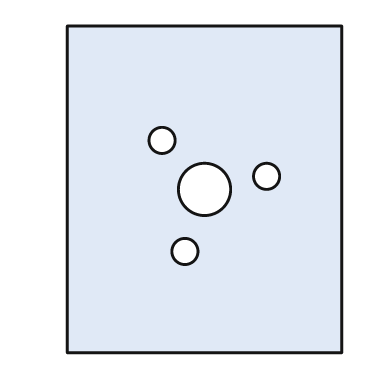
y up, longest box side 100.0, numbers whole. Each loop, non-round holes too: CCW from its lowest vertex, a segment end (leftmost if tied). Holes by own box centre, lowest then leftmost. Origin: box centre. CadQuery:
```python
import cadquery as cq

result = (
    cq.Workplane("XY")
    .moveTo(-42.0, -50.0)
    .lineTo(42.0, -50.0)
    .lineTo(42.0, 50.0)
    .lineTo(-42.0, 50.0)
    .close()
    .moveTo(-6.0, -19.0)
    .circle(4.0)
    .moveTo(0.0, 0.0)
    .circle(8.0)
    .moveTo(19.0, 4.0)
    .circle(4.0)
    .moveTo(-13.0, 15.0)
    .circle(4.0)
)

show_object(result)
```